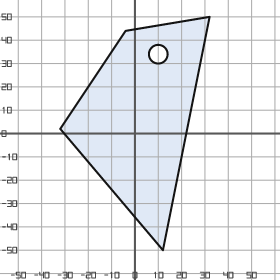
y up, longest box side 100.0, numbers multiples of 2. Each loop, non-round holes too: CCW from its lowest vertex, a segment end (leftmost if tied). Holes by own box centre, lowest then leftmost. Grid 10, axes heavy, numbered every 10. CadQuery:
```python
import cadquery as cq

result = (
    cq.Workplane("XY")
    .moveTo(12.0, -50.0)
    .lineTo(32.0, 50.0)
    .lineTo(-4.0, 44.0)
    .lineTo(-32.0, 2.0)
    .close()
    .moveTo(10.0, 34.0)
    .circle(4.0)
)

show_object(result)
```